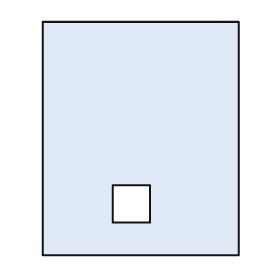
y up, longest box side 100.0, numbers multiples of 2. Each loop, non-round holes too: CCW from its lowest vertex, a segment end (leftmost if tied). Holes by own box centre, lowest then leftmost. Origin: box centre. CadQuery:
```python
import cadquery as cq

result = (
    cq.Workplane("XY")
    .moveTo(-42.0, -50.0)
    .lineTo(42.0, -50.0)
    .lineTo(42.0, 50.0)
    .lineTo(-42.0, 50.0)
    .close()
    .moveTo(-12.0, -36.0)
    .lineTo(4.0, -36.0)
    .lineTo(4.0, -20.0)
    .lineTo(-12.0, -20.0)
    .close()
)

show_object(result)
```